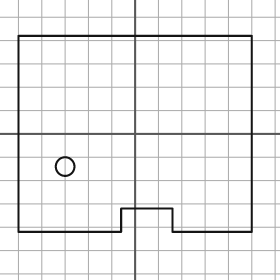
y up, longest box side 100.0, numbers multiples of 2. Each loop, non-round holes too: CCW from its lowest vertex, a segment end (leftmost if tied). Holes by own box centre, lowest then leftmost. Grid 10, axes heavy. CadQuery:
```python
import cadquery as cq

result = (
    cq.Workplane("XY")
    .moveTo(-50.0, -42.0)
    .lineTo(-6.0, -42.0)
    .lineTo(-6.0, -32.0)
    .lineTo(16.0, -32.0)
    .lineTo(16.0, -42.0)
    .lineTo(50.0, -42.0)
    .lineTo(50.0, 42.0)
    .lineTo(-50.0, 42.0)
    .close()
    .moveTo(-30.0, -14.0)
    .circle(4.0)
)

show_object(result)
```